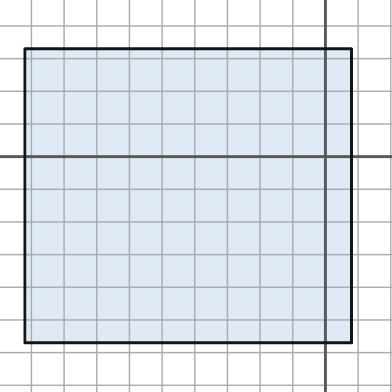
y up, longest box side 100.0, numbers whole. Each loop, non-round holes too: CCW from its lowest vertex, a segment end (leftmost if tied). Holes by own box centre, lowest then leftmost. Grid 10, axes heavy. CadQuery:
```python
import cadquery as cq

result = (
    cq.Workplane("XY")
    .moveTo(-92.0, -57.0)
    .lineTo(8.0, -57.0)
    .lineTo(8.0, 33.0)
    .lineTo(-92.0, 33.0)
    .close()
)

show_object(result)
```